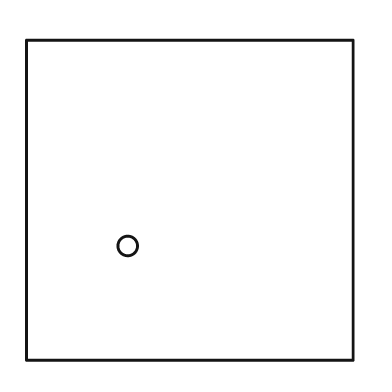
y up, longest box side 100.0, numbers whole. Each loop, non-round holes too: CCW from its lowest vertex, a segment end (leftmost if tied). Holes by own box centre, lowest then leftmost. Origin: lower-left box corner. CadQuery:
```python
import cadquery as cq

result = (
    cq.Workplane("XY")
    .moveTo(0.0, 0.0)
    .lineTo(100.0, 0.0)
    .lineTo(100.0, 98.0)
    .lineTo(0.0, 98.0)
    .close()
    .moveTo(31.0, 35.0)
    .circle(3.0)
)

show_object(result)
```